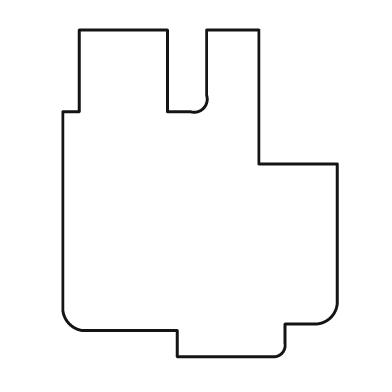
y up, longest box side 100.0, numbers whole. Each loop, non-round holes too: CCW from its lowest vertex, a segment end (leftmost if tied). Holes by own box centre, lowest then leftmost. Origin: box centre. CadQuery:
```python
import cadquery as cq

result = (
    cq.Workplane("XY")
    .moveTo(-7.0, -50.0)
    .lineTo(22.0, -50.0)
    .threePointArc((25.0, -49.0), (26.0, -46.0))
    .lineTo(26.0, -40.0)
    .lineTo(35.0, -40.0)
    .threePointArc((40.0, -38.0), (42.0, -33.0))
    .lineTo(42.0, 9.0)
    .lineTo(18.0, 9.0)
    .lineTo(18.0, 50.0)
    .lineTo(2.0, 50.0)
    .lineTo(2.0, 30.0)
    .threePointArc((1.0, 26.0), (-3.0, 25.0))
    .lineTo(-10.0, 25.0)
    .lineTo(-10.0, 50.0)
    .lineTo(-37.0, 50.0)
    .lineTo(-37.0, 25.0)
    .lineTo(-42.0, 25.0)
    .lineTo(-42.0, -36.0)
    .threePointArc((-40.0, -40.0), (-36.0, -42.0))
    .lineTo(-7.0, -42.0)
    .close()
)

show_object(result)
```